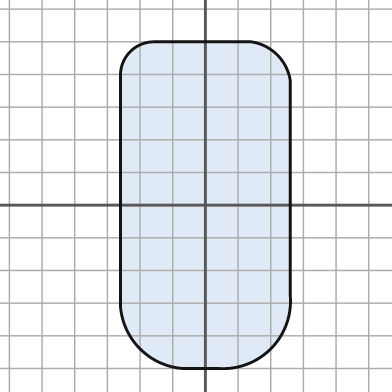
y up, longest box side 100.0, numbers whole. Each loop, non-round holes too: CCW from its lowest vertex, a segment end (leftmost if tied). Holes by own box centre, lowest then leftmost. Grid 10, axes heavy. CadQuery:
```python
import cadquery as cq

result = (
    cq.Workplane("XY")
    .moveTo(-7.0, -50.0)
    .lineTo(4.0, -50.0)
    .threePointArc((20.0, -44.0), (26.0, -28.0))
    .lineTo(26.0, 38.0)
    .threePointArc((22.0, 46.0), (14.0, 50.0))
    .lineTo(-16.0, 50.0)
    .threePointArc((-23.0, 47.0), (-26.0, 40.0))
    .lineTo(-26.0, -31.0)
    .threePointArc((-20.0, -44.0), (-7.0, -50.0))
    .close()
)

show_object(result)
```